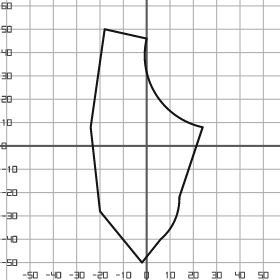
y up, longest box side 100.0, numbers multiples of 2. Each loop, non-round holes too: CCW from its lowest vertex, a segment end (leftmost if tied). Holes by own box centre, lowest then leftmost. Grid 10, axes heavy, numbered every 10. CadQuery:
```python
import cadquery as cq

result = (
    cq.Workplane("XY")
    .moveTo(-2.0, -50.0)
    .lineTo(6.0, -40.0)
    .threePointArc((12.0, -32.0), (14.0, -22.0))
    .lineTo(24.0, 8.0)
    .threePointArc((4.0, 22.0), (0.0, 46.0))
    .lineTo(-18.0, 50.0)
    .lineTo(-24.0, 8.0)
    .lineTo(-20.0, -28.0)
    .close()
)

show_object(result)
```